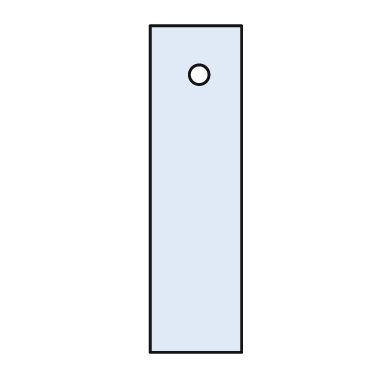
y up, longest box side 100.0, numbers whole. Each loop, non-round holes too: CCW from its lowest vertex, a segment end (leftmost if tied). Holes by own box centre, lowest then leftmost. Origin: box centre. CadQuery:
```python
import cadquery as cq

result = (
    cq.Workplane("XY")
    .moveTo(-14.0, -50.0)
    .lineTo(14.0, -50.0)
    .lineTo(14.0, 50.0)
    .lineTo(-14.0, 50.0)
    .close()
    .moveTo(1.0, 35.0)
    .circle(3.0)
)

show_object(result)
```